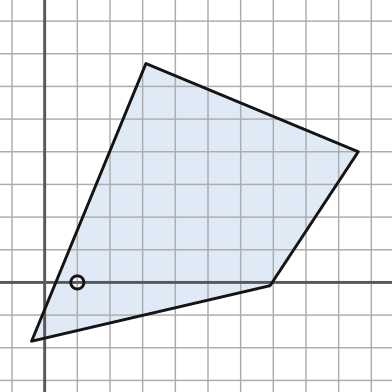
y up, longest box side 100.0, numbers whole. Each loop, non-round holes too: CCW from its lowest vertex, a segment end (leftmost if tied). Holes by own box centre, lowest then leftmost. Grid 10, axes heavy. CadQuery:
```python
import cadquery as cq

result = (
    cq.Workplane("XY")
    .moveTo(-4.0, -18.0)
    .lineTo(69.0, -1.0)
    .lineTo(96.0, 40.0)
    .lineTo(31.0, 67.0)
    .close()
    .moveTo(10.0, 0.0)
    .circle(2.0)
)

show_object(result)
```